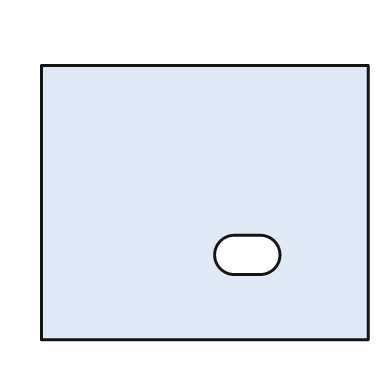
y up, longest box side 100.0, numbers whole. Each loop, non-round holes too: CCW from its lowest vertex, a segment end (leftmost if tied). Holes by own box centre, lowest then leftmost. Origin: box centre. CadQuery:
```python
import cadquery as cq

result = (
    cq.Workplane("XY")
    .moveTo(-50.0, -42.0)
    .lineTo(50.0, -42.0)
    .lineTo(50.0, 42.0)
    .lineTo(-50.0, 42.0)
    .close()
    .moveTo(9.0, -22.0)
    .lineTo(17.0, -22.0)
    .threePointArc((23.0, -16.0), (17.0, -10.0))
    .lineTo(9.0, -10.0)
    .threePointArc((3.0, -16.0), (9.0, -22.0))
    .close()
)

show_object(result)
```